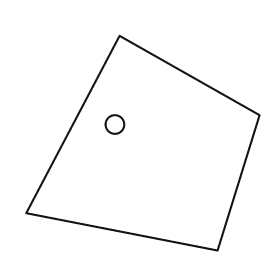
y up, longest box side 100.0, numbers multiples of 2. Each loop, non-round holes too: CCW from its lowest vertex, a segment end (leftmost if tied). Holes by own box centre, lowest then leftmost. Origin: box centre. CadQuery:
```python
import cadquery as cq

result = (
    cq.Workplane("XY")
    .moveTo(32.0, -46.0)
    .lineTo(50.0, 12.0)
    .lineTo(-10.0, 46.0)
    .lineTo(-50.0, -30.0)
    .close()
    .moveTo(-12.0, 8.0)
    .circle(4.0)
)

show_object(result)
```